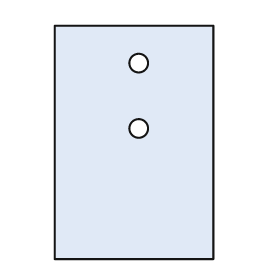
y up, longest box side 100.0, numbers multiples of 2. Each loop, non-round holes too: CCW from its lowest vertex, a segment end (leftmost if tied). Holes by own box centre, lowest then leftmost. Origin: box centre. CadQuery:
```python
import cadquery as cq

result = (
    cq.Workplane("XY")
    .moveTo(-34.0, -50.0)
    .lineTo(34.0, -50.0)
    .lineTo(34.0, 50.0)
    .lineTo(-34.0, 50.0)
    .close()
    .moveTo(2.0, 6.0)
    .circle(4.0)
    .moveTo(2.0, 34.0)
    .circle(4.0)
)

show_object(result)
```